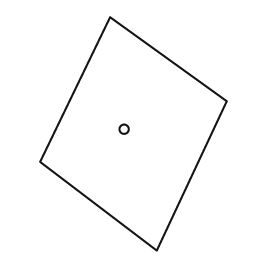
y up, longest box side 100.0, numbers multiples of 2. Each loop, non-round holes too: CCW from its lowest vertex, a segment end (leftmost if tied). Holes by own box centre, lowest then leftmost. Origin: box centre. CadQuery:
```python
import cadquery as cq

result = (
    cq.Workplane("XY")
    .moveTo(10.0, -50.0)
    .lineTo(40.0, 14.0)
    .lineTo(-10.0, 50.0)
    .lineTo(-40.0, -12.0)
    .close()
    .moveTo(-4.0, 2.0)
    .circle(2.0)
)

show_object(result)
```